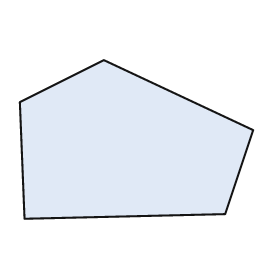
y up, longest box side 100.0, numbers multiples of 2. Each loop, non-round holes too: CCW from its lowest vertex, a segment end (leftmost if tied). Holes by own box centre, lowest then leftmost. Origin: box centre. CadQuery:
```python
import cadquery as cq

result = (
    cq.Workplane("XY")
    .moveTo(-48.0, -34.0)
    .lineTo(38.0, -32.0)
    .lineTo(50.0, 4.0)
    .lineTo(-14.0, 34.0)
    .lineTo(-50.0, 16.0)
    .close()
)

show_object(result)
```